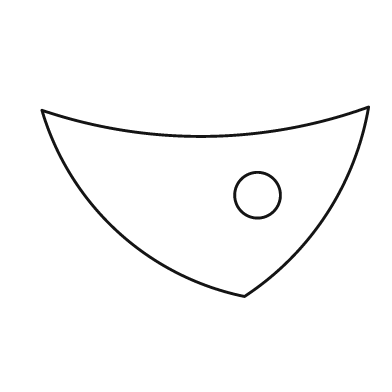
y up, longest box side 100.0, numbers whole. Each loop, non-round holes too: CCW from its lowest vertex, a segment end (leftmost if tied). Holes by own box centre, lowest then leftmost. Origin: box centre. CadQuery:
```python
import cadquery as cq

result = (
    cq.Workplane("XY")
    .moveTo(12.0, -29.0)
    .threePointArc((37.0, -4.0), (50.0, 29.0))
    .threePointArc((0.0, 20.0), (-50.0, 28.0))
    .threePointArc((-27.0, -9.0), (12.0, -29.0))
    .close()
    .moveTo(16.0, 2.0)
    .circle(7.0)
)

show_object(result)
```